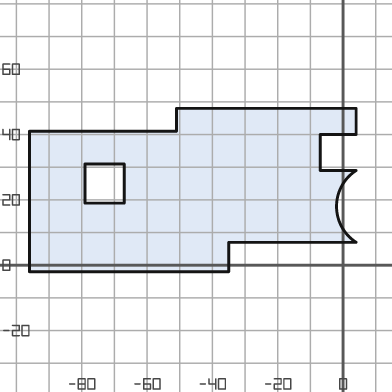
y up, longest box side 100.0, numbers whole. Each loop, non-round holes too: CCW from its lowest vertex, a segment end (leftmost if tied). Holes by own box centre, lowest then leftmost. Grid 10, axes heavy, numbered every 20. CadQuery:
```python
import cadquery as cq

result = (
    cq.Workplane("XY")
    .moveTo(-96.0, -2.0)
    .lineTo(-35.0, -2.0)
    .lineTo(-35.0, 7.0)
    .lineTo(4.0, 7.0)
    .threePointArc((-2.0, 18.0), (4.0, 29.0))
    .lineTo(-7.0, 29.0)
    .lineTo(-7.0, 40.0)
    .lineTo(4.0, 40.0)
    .lineTo(4.0, 48.0)
    .lineTo(-51.0, 48.0)
    .lineTo(-51.0, 41.0)
    .lineTo(-96.0, 41.0)
    .close()
    .moveTo(-79.0, 19.0)
    .lineTo(-67.0, 19.0)
    .lineTo(-67.0, 31.0)
    .lineTo(-79.0, 31.0)
    .close()
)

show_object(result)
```